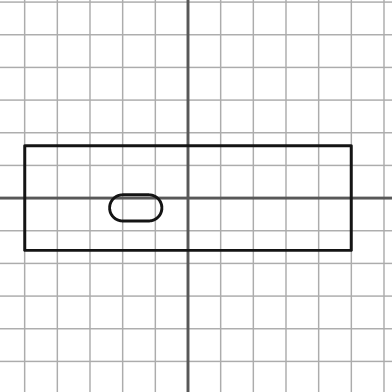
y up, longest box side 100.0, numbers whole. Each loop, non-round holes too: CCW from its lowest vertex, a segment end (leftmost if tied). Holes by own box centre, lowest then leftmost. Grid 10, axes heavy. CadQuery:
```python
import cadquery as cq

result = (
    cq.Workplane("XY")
    .moveTo(-50.0, -16.0)
    .lineTo(50.0, -16.0)
    .lineTo(50.0, 16.0)
    .lineTo(-50.0, 16.0)
    .close()
    .moveTo(-20.0, -7.0)
    .lineTo(-12.0, -7.0)
    .threePointArc((-8.0, -3.0), (-12.0, 1.0))
    .lineTo(-20.0, 1.0)
    .threePointArc((-24.0, -3.0), (-20.0, -7.0))
    .close()
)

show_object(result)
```